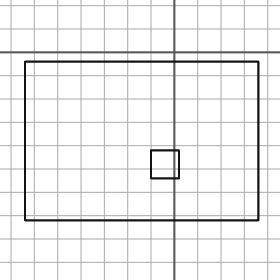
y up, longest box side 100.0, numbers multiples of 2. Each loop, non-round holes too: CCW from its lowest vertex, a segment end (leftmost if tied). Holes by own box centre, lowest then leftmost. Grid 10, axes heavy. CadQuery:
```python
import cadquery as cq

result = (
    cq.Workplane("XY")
    .moveTo(-64.0, -72.0)
    .lineTo(36.0, -72.0)
    .lineTo(36.0, -4.0)
    .lineTo(-64.0, -4.0)
    .close()
    .moveTo(-10.0, -54.0)
    .lineTo(2.0, -54.0)
    .lineTo(2.0, -42.0)
    .lineTo(-10.0, -42.0)
    .close()
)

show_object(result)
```